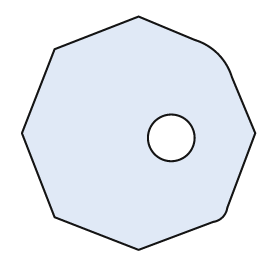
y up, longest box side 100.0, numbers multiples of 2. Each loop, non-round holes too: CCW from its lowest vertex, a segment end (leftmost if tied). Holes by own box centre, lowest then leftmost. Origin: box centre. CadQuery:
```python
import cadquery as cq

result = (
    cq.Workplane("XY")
    .moveTo(0.0, -50.0)
    .lineTo(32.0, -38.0)
    .threePointArc((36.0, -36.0), (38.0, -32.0))
    .lineTo(50.0, 0.0)
    .lineTo(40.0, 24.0)
    .threePointArc((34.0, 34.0), (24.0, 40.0))
    .lineTo(0.0, 50.0)
    .lineTo(-36.0, 36.0)
    .lineTo(-50.0, 0.0)
    .lineTo(-36.0, -36.0)
    .close()
    .moveTo(14.0, -2.0)
    .circle(10.0)
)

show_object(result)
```